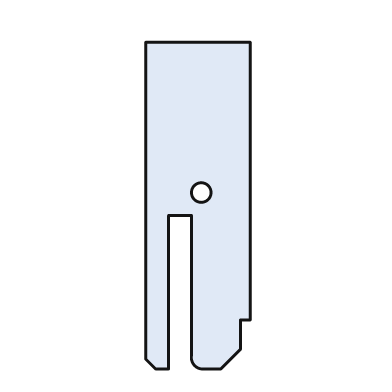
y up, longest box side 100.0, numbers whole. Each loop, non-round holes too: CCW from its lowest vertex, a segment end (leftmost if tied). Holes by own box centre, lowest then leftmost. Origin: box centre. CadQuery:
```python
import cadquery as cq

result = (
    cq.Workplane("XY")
    .moveTo(-13.0, -50.0)
    .lineTo(-9.0, -50.0)
    .lineTo(-9.0, -3.0)
    .lineTo(-2.0, -3.0)
    .lineTo(-2.0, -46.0)
    .threePointArc((-1.0, -49.0), (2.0, -50.0))
    .lineTo(7.0, -50.0)
    .lineTo(13.0, -44.0)
    .lineTo(13.0, -35.0)
    .lineTo(16.0, -35.0)
    .lineTo(16.0, 50.0)
    .lineTo(-16.0, 50.0)
    .lineTo(-16.0, -47.0)
    .close()
    .moveTo(1.0, 4.0)
    .circle(3.0)
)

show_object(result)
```